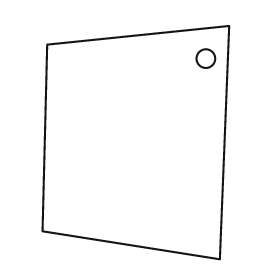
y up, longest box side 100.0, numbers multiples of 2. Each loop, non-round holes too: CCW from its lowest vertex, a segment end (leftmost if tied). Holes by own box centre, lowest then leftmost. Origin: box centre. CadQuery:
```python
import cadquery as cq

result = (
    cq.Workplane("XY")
    .moveTo(36.0, -50.0)
    .lineTo(40.0, 50.0)
    .lineTo(-38.0, 42.0)
    .lineTo(-40.0, -38.0)
    .close()
    .moveTo(30.0, 36.0)
    .circle(4.0)
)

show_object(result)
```